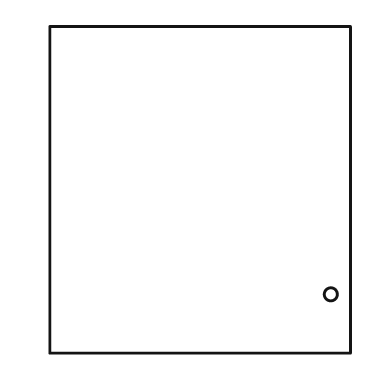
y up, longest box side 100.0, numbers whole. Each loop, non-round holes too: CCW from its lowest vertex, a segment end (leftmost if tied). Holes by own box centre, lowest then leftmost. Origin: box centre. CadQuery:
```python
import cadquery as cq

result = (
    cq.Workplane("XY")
    .moveTo(-46.0, -50.0)
    .lineTo(46.0, -50.0)
    .lineTo(46.0, 50.0)
    .lineTo(-46.0, 50.0)
    .close()
    .moveTo(40.0, -32.0)
    .circle(2.0)
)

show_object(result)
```